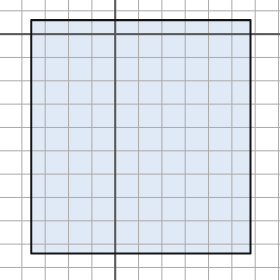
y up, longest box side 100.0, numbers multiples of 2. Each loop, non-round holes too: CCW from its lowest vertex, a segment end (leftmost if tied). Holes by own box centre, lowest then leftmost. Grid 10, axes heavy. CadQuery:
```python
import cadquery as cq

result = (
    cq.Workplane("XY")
    .moveTo(-36.0, -94.0)
    .lineTo(58.0, -94.0)
    .lineTo(58.0, 6.0)
    .lineTo(-36.0, 6.0)
    .close()
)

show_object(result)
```